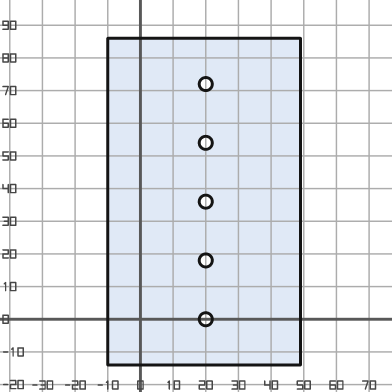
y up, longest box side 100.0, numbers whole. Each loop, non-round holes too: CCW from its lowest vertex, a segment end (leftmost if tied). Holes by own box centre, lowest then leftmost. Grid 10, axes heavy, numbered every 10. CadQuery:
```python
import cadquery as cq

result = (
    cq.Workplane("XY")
    .moveTo(-10.0, -14.0)
    .lineTo(49.0, -14.0)
    .lineTo(49.0, 86.0)
    .lineTo(-10.0, 86.0)
    .close()
    .moveTo(20.0, 0.0)
    .circle(2.0)
    .moveTo(20.0, 18.0)
    .circle(2.0)
    .moveTo(20.0, 36.0)
    .circle(2.0)
    .moveTo(20.0, 54.0)
    .circle(2.0)
    .moveTo(20.0, 72.0)
    .circle(2.0)
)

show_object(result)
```